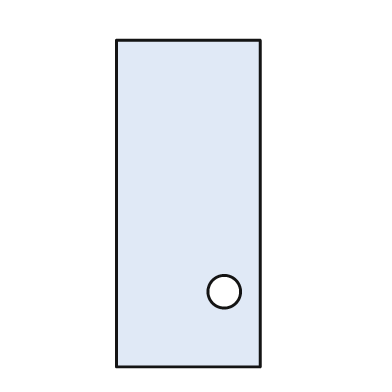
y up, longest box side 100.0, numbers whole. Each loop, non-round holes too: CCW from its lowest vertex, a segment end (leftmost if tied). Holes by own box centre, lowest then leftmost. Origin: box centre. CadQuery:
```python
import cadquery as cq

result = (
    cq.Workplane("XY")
    .moveTo(-22.0, -50.0)
    .lineTo(22.0, -50.0)
    .lineTo(22.0, 50.0)
    .lineTo(-22.0, 50.0)
    .close()
    .moveTo(11.0, -27.0)
    .circle(5.0)
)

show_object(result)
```